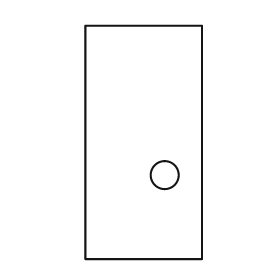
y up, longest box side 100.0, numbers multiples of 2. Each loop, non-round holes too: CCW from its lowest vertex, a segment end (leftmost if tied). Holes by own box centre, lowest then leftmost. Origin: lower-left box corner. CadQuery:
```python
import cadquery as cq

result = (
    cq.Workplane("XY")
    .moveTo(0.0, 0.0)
    .lineTo(50.0, 0.0)
    .lineTo(50.0, 100.0)
    .lineTo(0.0, 100.0)
    .close()
    .moveTo(34.0, 36.0)
    .circle(6.0)
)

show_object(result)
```